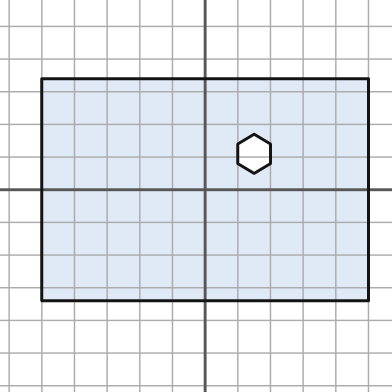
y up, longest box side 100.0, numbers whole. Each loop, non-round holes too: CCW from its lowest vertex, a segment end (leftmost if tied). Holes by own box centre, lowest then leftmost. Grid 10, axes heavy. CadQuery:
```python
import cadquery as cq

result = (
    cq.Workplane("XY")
    .moveTo(-50.0, -34.0)
    .lineTo(50.0, -34.0)
    .lineTo(50.0, 34.0)
    .lineTo(-50.0, 34.0)
    .close()
    .moveTo(15.0, 5.0)
    .lineTo(20.0, 8.0)
    .lineTo(20.0, 14.0)
    .lineTo(15.0, 17.0)
    .lineTo(10.0, 14.0)
    .lineTo(10.0, 8.0)
    .close()
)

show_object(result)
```